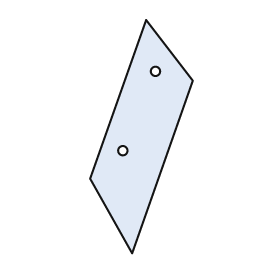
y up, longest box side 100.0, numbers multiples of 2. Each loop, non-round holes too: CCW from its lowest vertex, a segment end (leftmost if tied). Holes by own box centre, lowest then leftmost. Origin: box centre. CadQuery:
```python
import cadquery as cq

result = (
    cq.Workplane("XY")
    .moveTo(-4.0, -50.0)
    .lineTo(22.0, 24.0)
    .lineTo(2.0, 50.0)
    .lineTo(-22.0, -18.0)
    .close()
    .moveTo(-8.0, -6.0)
    .circle(2.0)
    .moveTo(6.0, 28.0)
    .circle(2.0)
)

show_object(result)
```